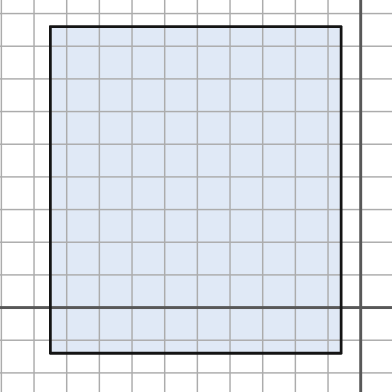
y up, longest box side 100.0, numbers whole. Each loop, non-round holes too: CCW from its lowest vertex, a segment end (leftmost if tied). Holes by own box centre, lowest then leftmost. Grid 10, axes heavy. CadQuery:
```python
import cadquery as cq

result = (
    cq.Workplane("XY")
    .moveTo(-95.0, -14.0)
    .lineTo(-6.0, -14.0)
    .lineTo(-6.0, 86.0)
    .lineTo(-95.0, 86.0)
    .close()
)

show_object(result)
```